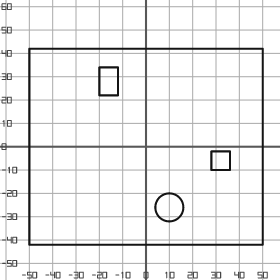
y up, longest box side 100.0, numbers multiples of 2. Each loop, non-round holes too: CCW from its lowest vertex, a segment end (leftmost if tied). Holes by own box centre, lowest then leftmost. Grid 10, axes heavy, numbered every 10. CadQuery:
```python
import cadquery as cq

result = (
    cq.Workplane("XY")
    .moveTo(-50.0, -42.0)
    .lineTo(50.0, -42.0)
    .lineTo(50.0, 42.0)
    .lineTo(-50.0, 42.0)
    .close()
    .moveTo(10.0, -26.0)
    .circle(6.0)
    .moveTo(28.0, -10.0)
    .lineTo(36.0, -10.0)
    .lineTo(36.0, -2.0)
    .lineTo(28.0, -2.0)
    .close()
    .moveTo(-20.0, 22.0)
    .lineTo(-12.0, 22.0)
    .lineTo(-12.0, 34.0)
    .lineTo(-20.0, 34.0)
    .close()
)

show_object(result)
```